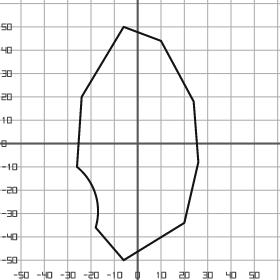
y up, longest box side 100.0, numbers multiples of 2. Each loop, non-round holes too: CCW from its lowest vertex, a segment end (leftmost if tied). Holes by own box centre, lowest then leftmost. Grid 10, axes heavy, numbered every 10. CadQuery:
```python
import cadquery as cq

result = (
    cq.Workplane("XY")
    .moveTo(-6.0, -50.0)
    .lineTo(20.0, -34.0)
    .lineTo(26.0, -8.0)
    .lineTo(24.0, 18.0)
    .lineTo(10.0, 44.0)
    .lineTo(-6.0, 50.0)
    .lineTo(-24.0, 20.0)
    .lineTo(-26.0, -10.0)
    .threePointArc((-18.0, -22.0), (-18.0, -36.0))
    .close()
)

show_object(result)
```